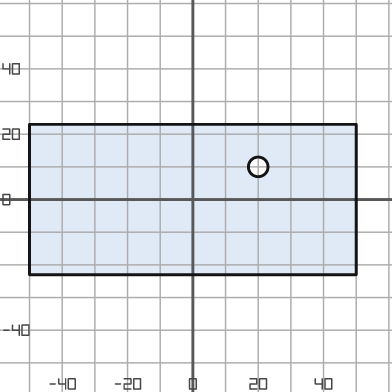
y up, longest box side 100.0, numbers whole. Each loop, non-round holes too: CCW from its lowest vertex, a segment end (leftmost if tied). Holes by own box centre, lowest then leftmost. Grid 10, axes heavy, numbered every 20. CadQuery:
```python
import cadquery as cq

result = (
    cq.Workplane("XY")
    .moveTo(-50.0, -23.0)
    .lineTo(50.0, -23.0)
    .lineTo(50.0, 23.0)
    .lineTo(-50.0, 23.0)
    .close()
    .moveTo(20.0, 10.0)
    .circle(3.0)
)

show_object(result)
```